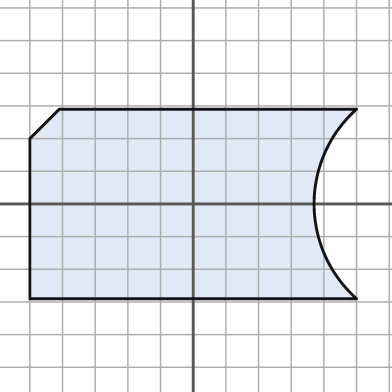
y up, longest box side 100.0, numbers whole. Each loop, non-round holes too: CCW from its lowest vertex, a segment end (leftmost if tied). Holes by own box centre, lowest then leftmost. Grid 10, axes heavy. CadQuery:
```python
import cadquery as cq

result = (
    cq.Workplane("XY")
    .moveTo(-50.0, -29.0)
    .lineTo(50.0, -29.0)
    .threePointArc((37.0, 0.0), (50.0, 29.0))
    .lineTo(-41.0, 29.0)
    .lineTo(-50.0, 20.0)
    .close()
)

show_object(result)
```